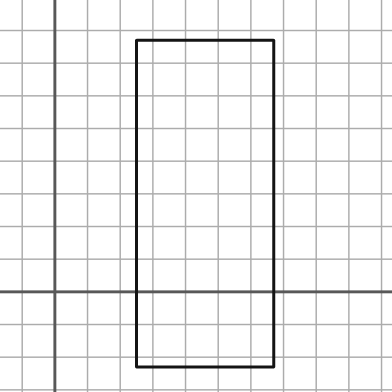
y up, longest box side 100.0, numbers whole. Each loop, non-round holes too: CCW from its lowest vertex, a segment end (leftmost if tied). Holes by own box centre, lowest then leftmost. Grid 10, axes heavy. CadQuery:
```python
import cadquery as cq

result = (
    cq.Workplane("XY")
    .moveTo(25.0, -23.0)
    .lineTo(67.0, -23.0)
    .lineTo(67.0, 77.0)
    .lineTo(25.0, 77.0)
    .close()
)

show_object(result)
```